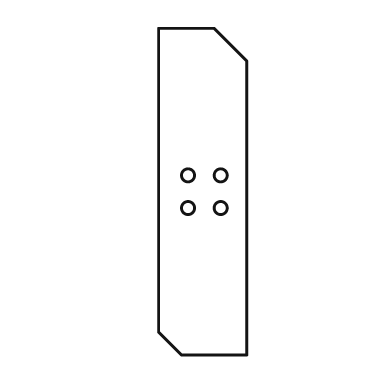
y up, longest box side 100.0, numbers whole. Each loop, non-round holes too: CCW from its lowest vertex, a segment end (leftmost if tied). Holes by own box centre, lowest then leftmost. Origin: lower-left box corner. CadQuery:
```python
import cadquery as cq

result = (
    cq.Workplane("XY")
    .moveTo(7.0, 0.0)
    .lineTo(27.0, 0.0)
    .lineTo(27.0, 90.0)
    .lineTo(17.0, 100.0)
    .lineTo(0.0, 100.0)
    .lineTo(0.0, 7.0)
    .close()
    .moveTo(9.0, 45.0)
    .circle(2.0)
    .moveTo(19.0, 45.0)
    .circle(2.0)
    .moveTo(9.0, 55.0)
    .circle(2.0)
    .moveTo(19.0, 55.0)
    .circle(2.0)
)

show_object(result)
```